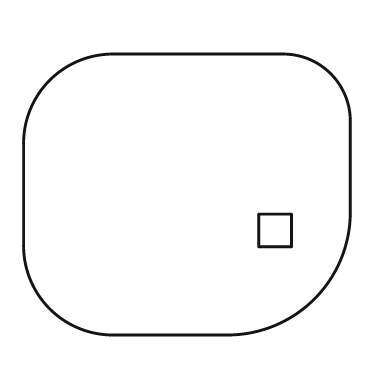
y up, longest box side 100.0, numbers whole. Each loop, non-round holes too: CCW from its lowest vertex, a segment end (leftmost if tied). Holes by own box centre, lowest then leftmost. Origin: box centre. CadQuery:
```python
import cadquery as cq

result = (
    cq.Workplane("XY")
    .moveTo(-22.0, -43.0)
    .lineTo(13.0, -43.0)
    .threePointArc((39.0, -32.0), (50.0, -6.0))
    .lineTo(50.0, 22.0)
    .threePointArc((44.0, 37.0), (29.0, 43.0))
    .lineTo(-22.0, 43.0)
    .threePointArc((-42.0, 35.0), (-50.0, 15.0))
    .lineTo(-50.0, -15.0)
    .threePointArc((-42.0, -35.0), (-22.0, -43.0))
    .close()
    .moveTo(22.0, -16.0)
    .lineTo(32.0, -16.0)
    .lineTo(32.0, -6.0)
    .lineTo(22.0, -6.0)
    .close()
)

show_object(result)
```